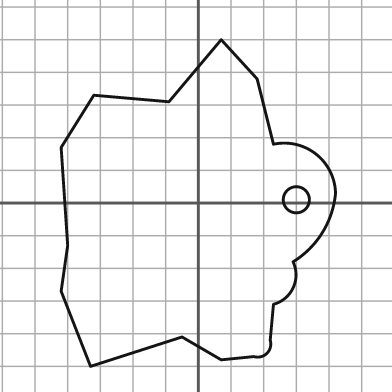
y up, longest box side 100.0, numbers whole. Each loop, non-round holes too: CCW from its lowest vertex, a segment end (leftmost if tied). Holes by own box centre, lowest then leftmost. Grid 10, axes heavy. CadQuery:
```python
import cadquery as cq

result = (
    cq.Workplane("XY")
    .moveTo(-33.0, -50.0)
    .lineTo(-5.0, -41.0)
    .lineTo(7.0, -48.0)
    .lineTo(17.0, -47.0)
    .threePointArc((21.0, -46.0), (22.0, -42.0))
    .lineTo(23.0, -31.0)
    .threePointArc((29.0, -26.0), (29.0, -18.0))
    .threePointArc((38.0, -9.0), (42.0, 3.0))
    .threePointArc((36.0, 15.0), (23.0, 18.0))
    .lineTo(18.0, 38.0)
    .lineTo(7.0, 50.0)
    .lineTo(-9.0, 31.0)
    .lineTo(-32.0, 33.0)
    .lineTo(-42.0, 17.0)
    .lineTo(-40.0, -13.0)
    .lineTo(-42.0, -27.0)
    .close()
    .moveTo(30.0, 1.0)
    .circle(4.0)
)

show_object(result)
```